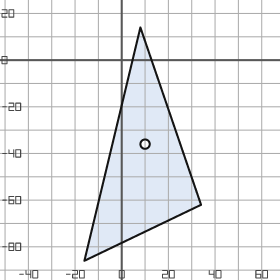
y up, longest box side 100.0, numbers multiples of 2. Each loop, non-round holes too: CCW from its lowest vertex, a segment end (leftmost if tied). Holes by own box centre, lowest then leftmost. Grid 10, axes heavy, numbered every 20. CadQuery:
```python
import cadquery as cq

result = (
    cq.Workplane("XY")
    .moveTo(-16.0, -86.0)
    .lineTo(34.0, -62.0)
    .lineTo(8.0, 14.0)
    .close()
    .moveTo(10.0, -36.0)
    .circle(2.0)
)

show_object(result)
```